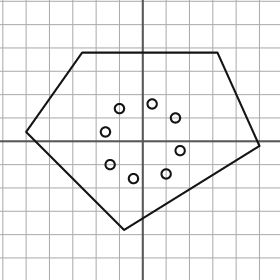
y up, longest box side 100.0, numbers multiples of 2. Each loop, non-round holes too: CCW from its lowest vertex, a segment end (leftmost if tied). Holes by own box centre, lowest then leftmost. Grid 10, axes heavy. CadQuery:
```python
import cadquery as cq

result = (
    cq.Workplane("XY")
    .moveTo(-8.0, -38.0)
    .lineTo(50.0, -2.0)
    .lineTo(32.0, 38.0)
    .lineTo(-26.0, 38.0)
    .lineTo(-50.0, 4.0)
    .close()
    .moveTo(-4.0, -16.0)
    .circle(2.0)
    .moveTo(10.0, -14.0)
    .circle(2.0)
    .moveTo(-14.0, -10.0)
    .circle(2.0)
    .moveTo(16.0, -4.0)
    .circle(2.0)
    .moveTo(-16.0, 4.0)
    .circle(2.0)
    .moveTo(14.0, 10.0)
    .circle(2.0)
    .moveTo(-10.0, 14.0)
    .circle(2.0)
    .moveTo(4.0, 16.0)
    .circle(2.0)
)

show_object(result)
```